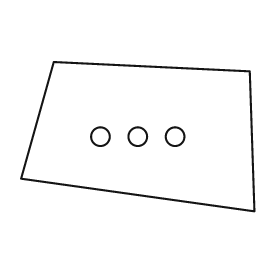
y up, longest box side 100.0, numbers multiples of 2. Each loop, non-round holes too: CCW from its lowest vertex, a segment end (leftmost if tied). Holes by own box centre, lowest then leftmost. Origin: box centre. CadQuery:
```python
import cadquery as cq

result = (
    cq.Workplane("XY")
    .moveTo(50.0, -32.0)
    .lineTo(48.0, 28.0)
    .lineTo(-36.0, 32.0)
    .lineTo(-50.0, -18.0)
    .close()
    .moveTo(-16.0, 0.0)
    .circle(4.0)
    .moveTo(0.0, 0.0)
    .circle(4.0)
    .moveTo(16.0, 0.0)
    .circle(4.0)
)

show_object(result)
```